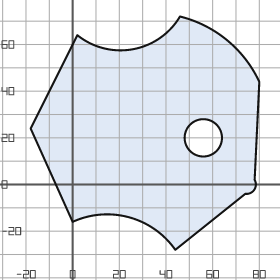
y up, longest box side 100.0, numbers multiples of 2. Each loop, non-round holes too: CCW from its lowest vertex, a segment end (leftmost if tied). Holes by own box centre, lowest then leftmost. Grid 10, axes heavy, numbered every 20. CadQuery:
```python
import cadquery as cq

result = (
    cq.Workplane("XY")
    .moveTo(44.0, -28.0)
    .lineTo(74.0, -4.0)
    .threePointArc((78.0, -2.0), (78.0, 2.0))
    .lineTo(80.0, 44.0)
    .threePointArc((66.0, 62.0), (46.0, 72.0))
    .threePointArc((26.0, 58.0), (2.0, 64.0))
    .lineTo(-18.0, 24.0)
    .lineTo(0.0, -16.0)
    .threePointArc((24.0, -14.0), (44.0, -28.0))
    .close()
    .moveTo(56.0, 20.0)
    .circle(8.0)
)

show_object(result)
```